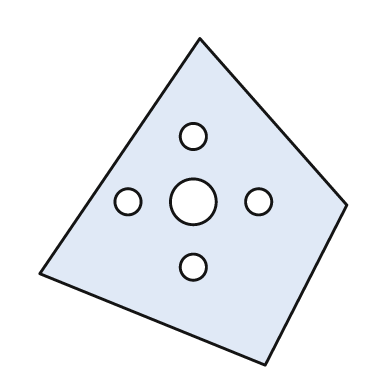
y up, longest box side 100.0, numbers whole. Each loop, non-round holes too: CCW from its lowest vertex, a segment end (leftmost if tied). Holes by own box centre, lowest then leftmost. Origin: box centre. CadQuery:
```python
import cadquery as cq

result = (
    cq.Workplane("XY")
    .moveTo(22.0, -50.0)
    .lineTo(47.0, -1.0)
    .lineTo(2.0, 50.0)
    .lineTo(-47.0, -22.0)
    .close()
    .moveTo(0.0, -20.0)
    .circle(4.0)
    .moveTo(-20.0, 0.0)
    .circle(4.0)
    .moveTo(0.0, 0.0)
    .circle(7.0)
    .moveTo(20.0, 0.0)
    .circle(4.0)
    .moveTo(0.0, 20.0)
    .circle(4.0)
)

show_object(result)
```